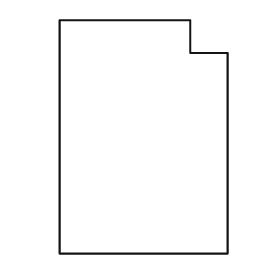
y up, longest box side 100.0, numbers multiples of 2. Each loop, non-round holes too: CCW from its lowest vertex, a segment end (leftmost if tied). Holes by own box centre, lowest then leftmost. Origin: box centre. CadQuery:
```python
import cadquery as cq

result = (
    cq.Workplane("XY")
    .moveTo(-36.0, -50.0)
    .lineTo(36.0, -50.0)
    .lineTo(36.0, 36.0)
    .lineTo(20.0, 36.0)
    .lineTo(20.0, 50.0)
    .lineTo(-36.0, 50.0)
    .close()
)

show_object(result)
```